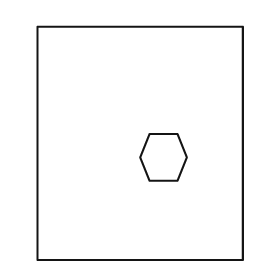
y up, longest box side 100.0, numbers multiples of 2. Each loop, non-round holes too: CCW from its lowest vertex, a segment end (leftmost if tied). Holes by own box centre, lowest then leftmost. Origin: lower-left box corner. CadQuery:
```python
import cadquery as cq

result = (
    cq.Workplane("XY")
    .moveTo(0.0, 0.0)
    .lineTo(88.0, 0.0)
    .lineTo(88.0, 100.0)
    .lineTo(0.0, 100.0)
    .close()
    .moveTo(48.0, 34.0)
    .lineTo(60.0, 34.0)
    .lineTo(64.0, 44.0)
    .lineTo(60.0, 54.0)
    .lineTo(48.0, 54.0)
    .lineTo(44.0, 44.0)
    .close()
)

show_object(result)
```